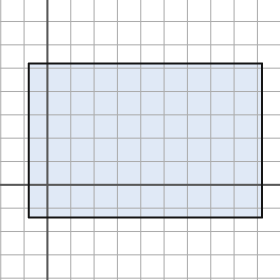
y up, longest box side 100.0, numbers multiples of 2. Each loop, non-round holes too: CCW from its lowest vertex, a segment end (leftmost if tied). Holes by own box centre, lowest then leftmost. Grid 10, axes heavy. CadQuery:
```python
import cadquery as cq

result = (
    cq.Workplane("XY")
    .moveTo(-8.0, -14.0)
    .lineTo(92.0, -14.0)
    .lineTo(92.0, 52.0)
    .lineTo(-8.0, 52.0)
    .close()
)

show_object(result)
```